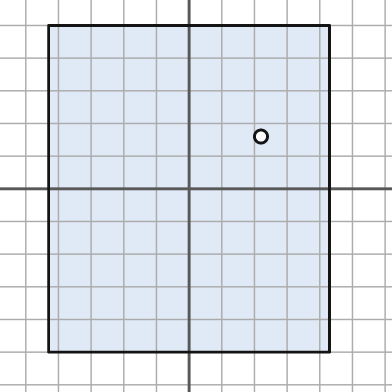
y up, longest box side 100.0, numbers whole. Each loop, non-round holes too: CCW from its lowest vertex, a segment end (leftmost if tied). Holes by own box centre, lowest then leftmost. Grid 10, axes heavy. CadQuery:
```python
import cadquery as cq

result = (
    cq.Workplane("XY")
    .moveTo(-43.0, -50.0)
    .lineTo(43.0, -50.0)
    .lineTo(43.0, 50.0)
    .lineTo(-43.0, 50.0)
    .close()
    .moveTo(22.0, 16.0)
    .circle(2.0)
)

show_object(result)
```